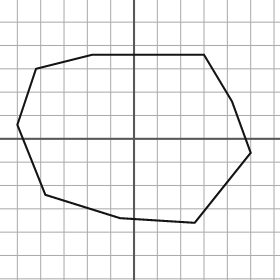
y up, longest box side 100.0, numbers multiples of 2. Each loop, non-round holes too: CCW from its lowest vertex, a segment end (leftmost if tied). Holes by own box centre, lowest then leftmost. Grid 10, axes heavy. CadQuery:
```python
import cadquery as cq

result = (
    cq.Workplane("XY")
    .moveTo(26.0, -36.0)
    .lineTo(50.0, -6.0)
    .lineTo(42.0, 16.0)
    .lineTo(30.0, 36.0)
    .lineTo(-18.0, 36.0)
    .lineTo(-42.0, 30.0)
    .lineTo(-50.0, 6.0)
    .lineTo(-38.0, -24.0)
    .lineTo(-6.0, -34.0)
    .close()
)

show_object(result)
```